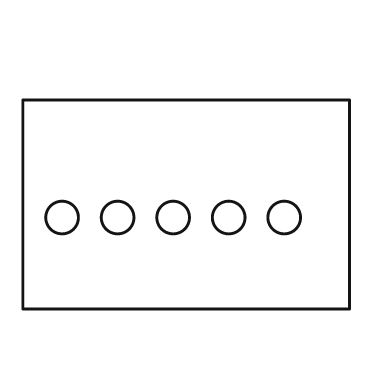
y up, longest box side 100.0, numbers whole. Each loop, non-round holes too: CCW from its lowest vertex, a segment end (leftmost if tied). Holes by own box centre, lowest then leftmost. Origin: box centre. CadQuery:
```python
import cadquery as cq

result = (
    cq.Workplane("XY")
    .moveTo(-50.0, -32.0)
    .lineTo(50.0, -32.0)
    .lineTo(50.0, 32.0)
    .lineTo(-50.0, 32.0)
    .close()
    .moveTo(-38.0, -4.0)
    .circle(5.0)
    .moveTo(-21.0, -4.0)
    .circle(5.0)
    .moveTo(-4.0, -4.0)
    .circle(5.0)
    .moveTo(13.0, -4.0)
    .circle(5.0)
    .moveTo(30.0, -4.0)
    .circle(5.0)
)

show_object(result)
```